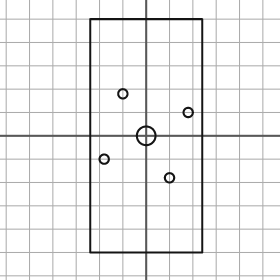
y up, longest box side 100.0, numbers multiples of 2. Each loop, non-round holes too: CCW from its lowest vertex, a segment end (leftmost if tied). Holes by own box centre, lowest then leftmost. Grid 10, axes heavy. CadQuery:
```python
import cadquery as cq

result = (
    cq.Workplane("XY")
    .moveTo(-24.0, -50.0)
    .lineTo(24.0, -50.0)
    .lineTo(24.0, 50.0)
    .lineTo(-24.0, 50.0)
    .close()
    .moveTo(10.0, -18.0)
    .circle(2.0)
    .moveTo(-18.0, -10.0)
    .circle(2.0)
    .moveTo(0.0, 0.0)
    .circle(4.0)
    .moveTo(18.0, 10.0)
    .circle(2.0)
    .moveTo(-10.0, 18.0)
    .circle(2.0)
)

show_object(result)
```